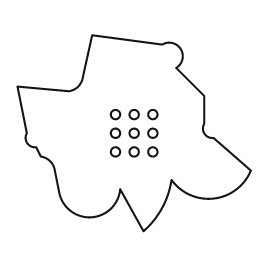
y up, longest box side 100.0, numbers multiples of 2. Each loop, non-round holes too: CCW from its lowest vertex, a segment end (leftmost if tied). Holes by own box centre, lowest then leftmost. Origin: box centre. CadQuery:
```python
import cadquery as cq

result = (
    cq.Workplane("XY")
    .moveTo(4.0, -42.0)
    .threePointArc((12.0, -32.0), (16.0, -20.0))
    .threePointArc((34.0, -28.0), (50.0, -16.0))
    .lineTo(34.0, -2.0)
    .threePointArc((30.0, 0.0), (30.0, 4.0))
    .lineTo(30.0, 16.0)
    .lineTo(18.0, 28.0)
    .threePointArc((20.0, 36.0), (12.0, 38.0))
    .lineTo(-18.0, 42.0)
    .lineTo(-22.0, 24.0)
    .threePointArc((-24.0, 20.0), (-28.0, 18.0))
    .lineTo(-50.0, 20.0)
    .lineTo(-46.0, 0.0)
    .threePointArc((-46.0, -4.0), (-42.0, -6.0))
    .lineTo(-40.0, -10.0)
    .threePointArc((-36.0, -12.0), (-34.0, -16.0))
    .lineTo(-32.0, -26.0)
    .threePointArc((-18.0, -36.0), (-6.0, -24.0))
    .close()
    .moveTo(-8.0, -8.0)
    .circle(2.0)
    .moveTo(0.0, -8.0)
    .circle(2.0)
    .moveTo(8.0, -8.0)
    .circle(2.0)
    .moveTo(-8.0, 0.0)
    .circle(2.0)
    .moveTo(0.0, 0.0)
    .circle(2.0)
    .moveTo(8.0, 0.0)
    .circle(2.0)
    .moveTo(-8.0, 8.0)
    .circle(2.0)
    .moveTo(0.0, 8.0)
    .circle(2.0)
    .moveTo(8.0, 8.0)
    .circle(2.0)
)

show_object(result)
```